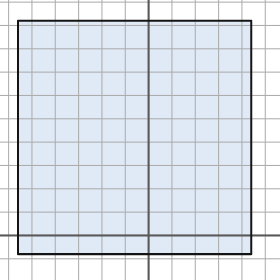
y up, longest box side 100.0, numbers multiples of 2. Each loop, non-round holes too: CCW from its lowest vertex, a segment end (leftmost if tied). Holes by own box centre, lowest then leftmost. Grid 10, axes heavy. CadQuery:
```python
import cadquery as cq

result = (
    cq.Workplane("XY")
    .moveTo(-56.0, -8.0)
    .lineTo(44.0, -8.0)
    .lineTo(44.0, 92.0)
    .lineTo(-56.0, 92.0)
    .close()
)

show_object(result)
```